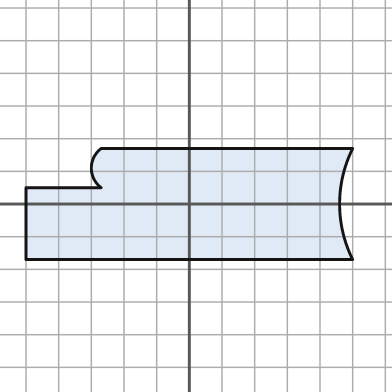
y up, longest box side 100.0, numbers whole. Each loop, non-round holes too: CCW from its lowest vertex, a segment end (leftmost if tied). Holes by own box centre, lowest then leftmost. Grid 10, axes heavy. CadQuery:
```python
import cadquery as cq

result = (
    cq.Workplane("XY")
    .moveTo(-50.0, -17.0)
    .lineTo(50.0, -17.0)
    .threePointArc((46.0, 0.0), (50.0, 17.0))
    .lineTo(-27.0, 17.0)
    .threePointArc((-30.0, 11.0), (-27.0, 5.0))
    .lineTo(-50.0, 5.0)
    .close()
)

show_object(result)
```